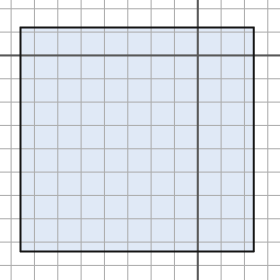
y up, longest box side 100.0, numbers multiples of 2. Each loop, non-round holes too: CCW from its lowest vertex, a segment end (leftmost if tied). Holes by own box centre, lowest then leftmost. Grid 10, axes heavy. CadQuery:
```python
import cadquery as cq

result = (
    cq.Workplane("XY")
    .moveTo(-76.0, -84.0)
    .lineTo(24.0, -84.0)
    .lineTo(24.0, 12.0)
    .lineTo(-76.0, 12.0)
    .close()
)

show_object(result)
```